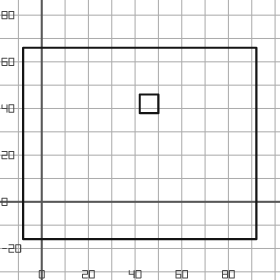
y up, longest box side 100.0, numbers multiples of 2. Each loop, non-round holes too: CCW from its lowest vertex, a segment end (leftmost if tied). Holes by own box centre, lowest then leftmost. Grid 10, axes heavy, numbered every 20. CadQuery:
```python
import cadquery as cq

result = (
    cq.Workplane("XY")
    .moveTo(-8.0, -16.0)
    .lineTo(92.0, -16.0)
    .lineTo(92.0, 66.0)
    .lineTo(-8.0, 66.0)
    .close()
    .moveTo(42.0, 38.0)
    .lineTo(50.0, 38.0)
    .lineTo(50.0, 46.0)
    .lineTo(42.0, 46.0)
    .close()
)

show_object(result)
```